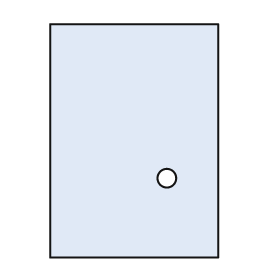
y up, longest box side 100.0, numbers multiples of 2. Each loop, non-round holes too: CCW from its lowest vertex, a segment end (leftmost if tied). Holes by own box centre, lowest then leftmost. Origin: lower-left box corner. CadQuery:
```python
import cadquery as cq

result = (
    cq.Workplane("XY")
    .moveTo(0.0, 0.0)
    .lineTo(72.0, 0.0)
    .lineTo(72.0, 100.0)
    .lineTo(0.0, 100.0)
    .close()
    .moveTo(50.0, 34.0)
    .circle(4.0)
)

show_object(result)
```